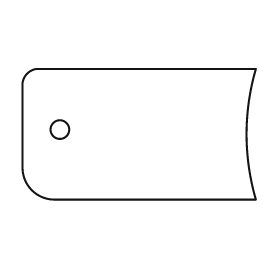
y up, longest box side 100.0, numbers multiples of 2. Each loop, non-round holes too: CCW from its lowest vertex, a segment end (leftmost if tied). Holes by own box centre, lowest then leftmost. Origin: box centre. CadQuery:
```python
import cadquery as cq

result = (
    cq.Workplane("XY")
    .moveTo(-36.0, -28.0)
    .lineTo(50.0, -28.0)
    .threePointArc((46.0, 0.0), (50.0, 28.0))
    .lineTo(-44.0, 28.0)
    .threePointArc((-48.0, 26.0), (-50.0, 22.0))
    .lineTo(-50.0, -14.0)
    .threePointArc((-46.0, -24.0), (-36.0, -28.0))
    .close()
    .moveTo(-34.0, 2.0)
    .circle(4.0)
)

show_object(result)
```